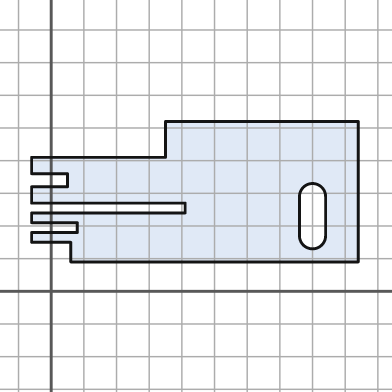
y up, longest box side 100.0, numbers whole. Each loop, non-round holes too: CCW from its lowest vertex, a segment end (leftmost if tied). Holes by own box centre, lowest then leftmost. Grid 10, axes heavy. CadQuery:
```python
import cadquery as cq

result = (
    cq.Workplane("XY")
    .moveTo(6.0, 9.0)
    .lineTo(94.0, 9.0)
    .lineTo(94.0, 52.0)
    .lineTo(35.0, 52.0)
    .lineTo(35.0, 41.0)
    .lineTo(-6.0, 41.0)
    .lineTo(-6.0, 36.0)
    .lineTo(5.0, 36.0)
    .lineTo(5.0, 32.0)
    .lineTo(-6.0, 32.0)
    .lineTo(-6.0, 27.0)
    .lineTo(41.0, 27.0)
    .lineTo(41.0, 24.0)
    .lineTo(-6.0, 24.0)
    .lineTo(-6.0, 21.0)
    .lineTo(8.0, 21.0)
    .lineTo(8.0, 18.0)
    .lineTo(-6.0, 18.0)
    .lineTo(-6.0, 15.0)
    .lineTo(6.0, 15.0)
    .close()
    .moveTo(76.0, 17.0)
    .threePointArc((80.0, 13.0), (84.0, 17.0))
    .lineTo(84.0, 29.0)
    .threePointArc((80.0, 33.0), (76.0, 29.0))
    .close()
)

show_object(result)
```